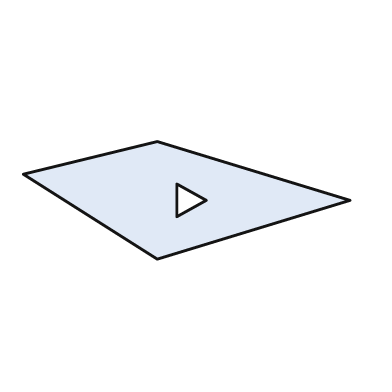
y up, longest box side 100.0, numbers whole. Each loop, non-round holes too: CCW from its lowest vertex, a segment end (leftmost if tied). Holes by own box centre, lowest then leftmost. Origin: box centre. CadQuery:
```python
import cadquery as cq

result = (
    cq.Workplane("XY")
    .moveTo(-9.0, -18.0)
    .lineTo(50.0, 0.0)
    .lineTo(-9.0, 18.0)
    .lineTo(-50.0, 8.0)
    .close()
    .moveTo(-3.0, -5.0)
    .lineTo(6.0, 0.0)
    .lineTo(-3.0, 5.0)
    .close()
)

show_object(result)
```